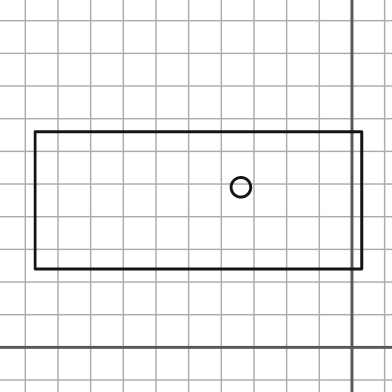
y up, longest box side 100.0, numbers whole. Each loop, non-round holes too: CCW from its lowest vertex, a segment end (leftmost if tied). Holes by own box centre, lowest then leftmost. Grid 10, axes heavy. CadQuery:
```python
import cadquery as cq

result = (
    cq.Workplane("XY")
    .moveTo(-97.0, 24.0)
    .lineTo(3.0, 24.0)
    .lineTo(3.0, 66.0)
    .lineTo(-97.0, 66.0)
    .close()
    .moveTo(-34.0, 49.0)
    .circle(3.0)
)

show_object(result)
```